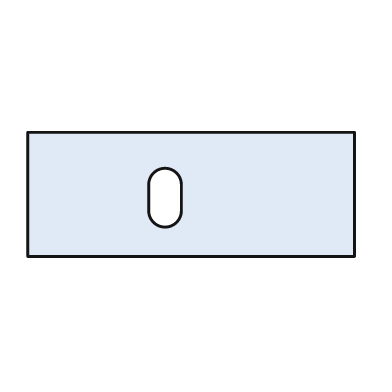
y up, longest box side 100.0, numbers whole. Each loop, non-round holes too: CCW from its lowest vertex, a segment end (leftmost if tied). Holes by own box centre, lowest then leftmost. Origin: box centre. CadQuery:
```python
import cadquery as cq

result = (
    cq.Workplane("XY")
    .moveTo(-50.0, -19.0)
    .lineTo(50.0, -19.0)
    .lineTo(50.0, 19.0)
    .lineTo(-50.0, 19.0)
    .close()
    .moveTo(-13.0, -5.0)
    .threePointArc((-8.0, -10.0), (-3.0, -5.0))
    .lineTo(-3.0, 3.0)
    .threePointArc((-8.0, 8.0), (-13.0, 3.0))
    .close()
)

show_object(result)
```